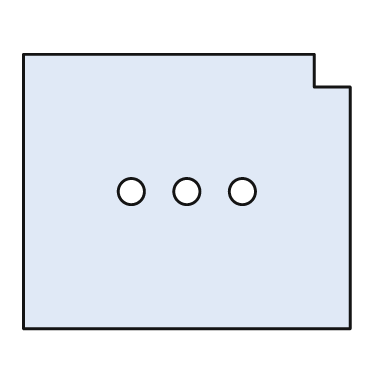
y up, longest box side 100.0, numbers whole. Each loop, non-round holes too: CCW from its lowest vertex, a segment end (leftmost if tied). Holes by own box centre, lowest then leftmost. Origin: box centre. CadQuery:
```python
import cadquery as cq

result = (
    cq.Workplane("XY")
    .moveTo(-50.0, -42.0)
    .lineTo(50.0, -42.0)
    .lineTo(50.0, 32.0)
    .lineTo(39.0, 32.0)
    .lineTo(39.0, 42.0)
    .lineTo(-50.0, 42.0)
    .close()
    .moveTo(-17.0, 0.0)
    .circle(4.0)
    .moveTo(0.0, 0.0)
    .circle(4.0)
    .moveTo(17.0, 0.0)
    .circle(4.0)
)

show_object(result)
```